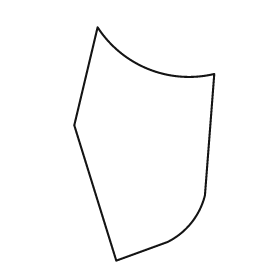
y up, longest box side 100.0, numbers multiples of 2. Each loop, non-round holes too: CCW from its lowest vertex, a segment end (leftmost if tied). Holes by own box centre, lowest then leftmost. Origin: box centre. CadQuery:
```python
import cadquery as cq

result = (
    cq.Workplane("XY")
    .moveTo(-12.0, -50.0)
    .lineTo(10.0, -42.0)
    .threePointArc((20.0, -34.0), (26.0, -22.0))
    .lineTo(30.0, 30.0)
    .threePointArc((2.0, 32.0), (-20.0, 50.0))
    .lineTo(-30.0, 8.0)
    .close()
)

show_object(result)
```